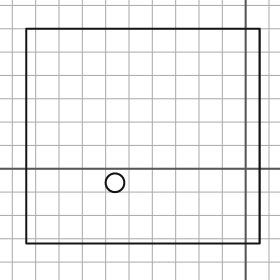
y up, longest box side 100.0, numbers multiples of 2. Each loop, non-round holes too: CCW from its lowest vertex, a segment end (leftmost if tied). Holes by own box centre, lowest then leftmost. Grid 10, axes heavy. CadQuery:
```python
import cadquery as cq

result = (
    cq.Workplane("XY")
    .moveTo(-94.0, -32.0)
    .lineTo(6.0, -32.0)
    .lineTo(6.0, 60.0)
    .lineTo(-94.0, 60.0)
    .close()
    .moveTo(-56.0, -6.0)
    .circle(4.0)
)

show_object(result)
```